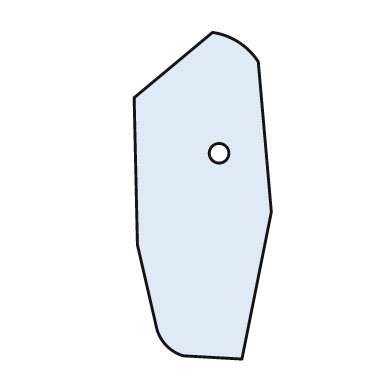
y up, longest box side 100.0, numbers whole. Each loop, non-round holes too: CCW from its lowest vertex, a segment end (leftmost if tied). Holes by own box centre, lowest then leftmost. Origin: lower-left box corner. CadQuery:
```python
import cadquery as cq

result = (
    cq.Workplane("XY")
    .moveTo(33.0, 0.0)
    .lineTo(42.0, 45.0)
    .lineTo(38.0, 91.0)
    .threePointArc((32.0, 97.0), (24.0, 100.0))
    .lineTo(0.0, 80.0)
    .lineTo(1.0, 35.0)
    .lineTo(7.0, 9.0)
    .threePointArc((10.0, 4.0), (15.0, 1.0))
    .close()
    .moveTo(26.0, 63.0)
    .circle(3.0)
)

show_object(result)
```